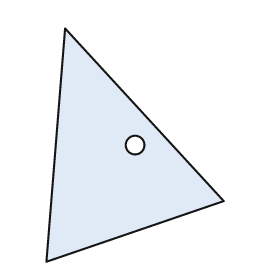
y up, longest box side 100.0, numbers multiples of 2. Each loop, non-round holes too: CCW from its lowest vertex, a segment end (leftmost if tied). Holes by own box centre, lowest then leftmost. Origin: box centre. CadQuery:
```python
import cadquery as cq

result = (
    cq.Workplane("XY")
    .moveTo(-38.0, -50.0)
    .lineTo(38.0, -24.0)
    .lineTo(-30.0, 50.0)
    .close()
    .moveTo(0.0, 0.0)
    .circle(4.0)
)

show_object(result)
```